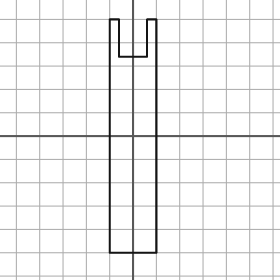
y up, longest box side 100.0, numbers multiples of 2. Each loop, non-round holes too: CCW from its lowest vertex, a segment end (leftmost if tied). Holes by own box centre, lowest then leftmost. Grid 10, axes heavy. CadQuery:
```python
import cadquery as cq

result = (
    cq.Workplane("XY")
    .moveTo(-10.0, -50.0)
    .lineTo(10.0, -50.0)
    .lineTo(10.0, 50.0)
    .lineTo(6.0, 50.0)
    .lineTo(6.0, 34.0)
    .lineTo(-6.0, 34.0)
    .lineTo(-6.0, 50.0)
    .lineTo(-10.0, 50.0)
    .close()
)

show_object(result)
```